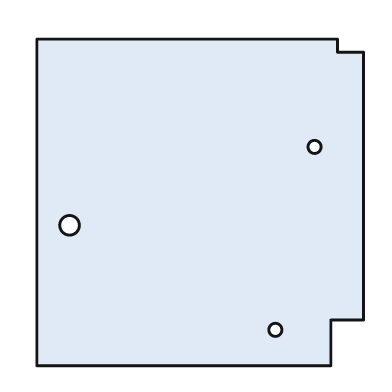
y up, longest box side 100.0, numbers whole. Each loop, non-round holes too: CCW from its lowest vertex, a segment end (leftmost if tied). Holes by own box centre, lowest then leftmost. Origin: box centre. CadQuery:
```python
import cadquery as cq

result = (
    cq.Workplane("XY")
    .moveTo(-50.0, -50.0)
    .lineTo(40.0, -50.0)
    .lineTo(40.0, -36.0)
    .lineTo(50.0, -36.0)
    .lineTo(50.0, 46.0)
    .lineTo(42.0, 46.0)
    .lineTo(42.0, 50.0)
    .lineTo(-50.0, 50.0)
    .close()
    .moveTo(23.0, -39.0)
    .circle(2.0)
    .moveTo(-40.0, -7.0)
    .circle(3.0)
    .moveTo(35.0, 17.0)
    .circle(2.0)
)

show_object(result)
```